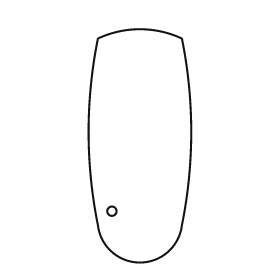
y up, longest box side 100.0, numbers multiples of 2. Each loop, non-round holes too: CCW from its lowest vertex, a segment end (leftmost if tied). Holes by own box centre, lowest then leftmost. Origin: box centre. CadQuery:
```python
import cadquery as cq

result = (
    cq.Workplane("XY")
    .moveTo(-18.0, -34.0)
    .threePointArc((0.0, -50.0), (18.0, -34.0))
    .threePointArc((22.0, 6.0), (18.0, 46.0))
    .threePointArc((0.0, 50.0), (-18.0, 46.0))
    .threePointArc((-22.0, 6.0), (-18.0, -34.0))
    .close()
    .moveTo(-12.0, -28.0)
    .circle(2.0)
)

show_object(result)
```